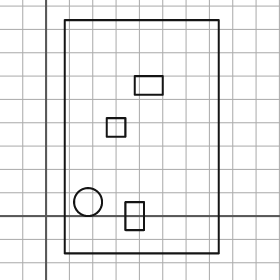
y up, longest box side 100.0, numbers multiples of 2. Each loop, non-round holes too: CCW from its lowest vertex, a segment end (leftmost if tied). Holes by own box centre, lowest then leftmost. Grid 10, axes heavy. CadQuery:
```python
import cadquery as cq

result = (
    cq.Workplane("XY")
    .moveTo(8.0, -16.0)
    .lineTo(74.0, -16.0)
    .lineTo(74.0, 84.0)
    .lineTo(8.0, 84.0)
    .close()
    .moveTo(34.0, -6.0)
    .lineTo(42.0, -6.0)
    .lineTo(42.0, 6.0)
    .lineTo(34.0, 6.0)
    .close()
    .moveTo(18.0, 6.0)
    .circle(6.0)
    .moveTo(26.0, 34.0)
    .lineTo(34.0, 34.0)
    .lineTo(34.0, 42.0)
    .lineTo(26.0, 42.0)
    .close()
    .moveTo(38.0, 52.0)
    .lineTo(50.0, 52.0)
    .lineTo(50.0, 60.0)
    .lineTo(38.0, 60.0)
    .close()
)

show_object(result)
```